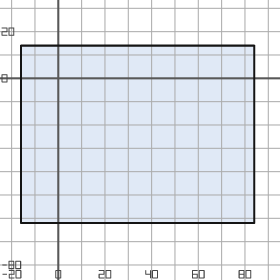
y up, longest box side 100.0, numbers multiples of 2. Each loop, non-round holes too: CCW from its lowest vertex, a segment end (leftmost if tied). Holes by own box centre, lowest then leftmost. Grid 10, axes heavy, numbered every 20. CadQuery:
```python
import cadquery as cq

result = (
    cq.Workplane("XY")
    .moveTo(-16.0, -62.0)
    .lineTo(84.0, -62.0)
    .lineTo(84.0, 14.0)
    .lineTo(-16.0, 14.0)
    .close()
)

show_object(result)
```